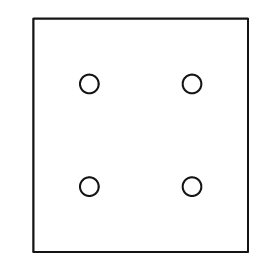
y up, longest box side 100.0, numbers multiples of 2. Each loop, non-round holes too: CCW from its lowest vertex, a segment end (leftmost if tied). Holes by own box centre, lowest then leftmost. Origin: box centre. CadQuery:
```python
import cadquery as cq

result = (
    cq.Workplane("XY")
    .moveTo(-46.0, -50.0)
    .lineTo(46.0, -50.0)
    .lineTo(46.0, 50.0)
    .lineTo(-46.0, 50.0)
    .close()
    .moveTo(-22.0, -22.0)
    .circle(4.0)
    .moveTo(22.0, -22.0)
    .circle(4.0)
    .moveTo(-22.0, 22.0)
    .circle(4.0)
    .moveTo(22.0, 22.0)
    .circle(4.0)
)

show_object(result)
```